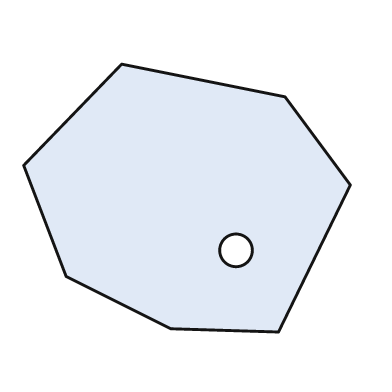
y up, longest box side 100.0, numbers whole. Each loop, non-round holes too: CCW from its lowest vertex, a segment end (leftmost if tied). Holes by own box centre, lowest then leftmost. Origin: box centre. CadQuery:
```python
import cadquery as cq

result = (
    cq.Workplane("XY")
    .moveTo(28.0, -41.0)
    .lineTo(50.0, 4.0)
    .lineTo(30.0, 31.0)
    .lineTo(-20.0, 41.0)
    .lineTo(-50.0, 10.0)
    .lineTo(-37.0, -24.0)
    .lineTo(-5.0, -40.0)
    .close()
    .moveTo(15.0, -16.0)
    .circle(5.0)
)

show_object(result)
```